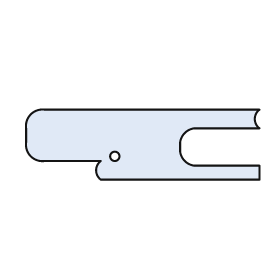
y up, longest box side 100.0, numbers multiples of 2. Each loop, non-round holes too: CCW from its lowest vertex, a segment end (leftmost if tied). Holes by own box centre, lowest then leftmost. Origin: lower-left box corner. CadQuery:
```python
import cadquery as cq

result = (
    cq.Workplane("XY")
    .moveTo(32.0, 0.0)
    .lineTo(100.0, 0.0)
    .lineTo(100.0, 6.0)
    .lineTo(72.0, 6.0)
    .threePointArc((68.0, 8.0), (66.0, 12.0))
    .lineTo(66.0, 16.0)
    .threePointArc((68.0, 20.0), (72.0, 22.0))
    .lineTo(100.0, 22.0)
    .threePointArc((98.0, 26.0), (100.0, 30.0))
    .lineTo(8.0, 30.0)
    .threePointArc((2.0, 28.0), (0.0, 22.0))
    .lineTo(0.0, 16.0)
    .threePointArc((2.0, 10.0), (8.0, 8.0))
    .lineTo(32.0, 8.0)
    .threePointArc((30.0, 4.0), (32.0, 0.0))
    .close()
    .moveTo(38.0, 10.0)
    .circle(2.0)
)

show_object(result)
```